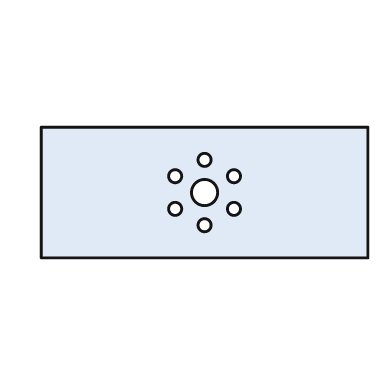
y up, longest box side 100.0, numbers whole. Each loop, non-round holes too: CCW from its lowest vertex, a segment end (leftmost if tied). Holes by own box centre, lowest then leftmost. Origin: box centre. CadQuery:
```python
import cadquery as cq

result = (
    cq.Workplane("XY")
    .moveTo(-50.0, -20.0)
    .lineTo(50.0, -20.0)
    .lineTo(50.0, 20.0)
    .lineTo(-50.0, 20.0)
    .close()
    .moveTo(0.0, -10.0)
    .circle(2.0)
    .moveTo(-9.0, -5.0)
    .circle(2.0)
    .moveTo(9.0, -5.0)
    .circle(2.0)
    .moveTo(0.0, 0.0)
    .circle(4.0)
    .moveTo(-9.0, 5.0)
    .circle(2.0)
    .moveTo(9.0, 5.0)
    .circle(2.0)
    .moveTo(0.0, 10.0)
    .circle(2.0)
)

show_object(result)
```